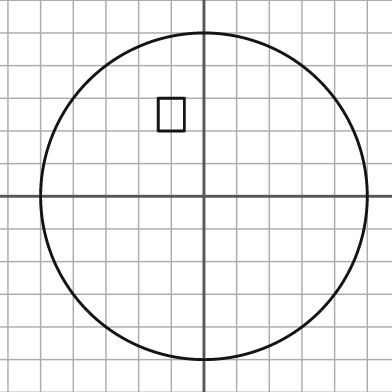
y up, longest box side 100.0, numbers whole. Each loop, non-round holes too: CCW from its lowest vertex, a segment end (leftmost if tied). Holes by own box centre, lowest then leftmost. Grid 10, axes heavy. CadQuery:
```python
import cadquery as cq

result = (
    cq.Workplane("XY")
    .moveTo(0.0, 0.0)
    .circle(50.0)
    .moveTo(-14.0, 20.0)
    .lineTo(-6.0, 20.0)
    .lineTo(-6.0, 30.0)
    .lineTo(-14.0, 30.0)
    .close()
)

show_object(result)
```